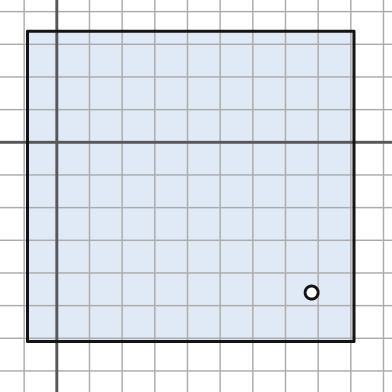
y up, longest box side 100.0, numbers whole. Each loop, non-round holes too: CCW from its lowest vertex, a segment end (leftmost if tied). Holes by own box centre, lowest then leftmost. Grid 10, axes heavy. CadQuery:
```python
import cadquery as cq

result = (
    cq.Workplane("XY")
    .moveTo(-9.0, -61.0)
    .lineTo(91.0, -61.0)
    .lineTo(91.0, 34.0)
    .lineTo(-9.0, 34.0)
    .close()
    .moveTo(78.0, -46.0)
    .circle(2.0)
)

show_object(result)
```